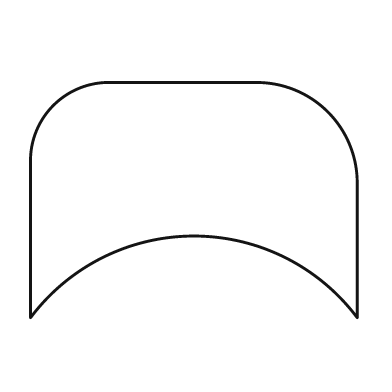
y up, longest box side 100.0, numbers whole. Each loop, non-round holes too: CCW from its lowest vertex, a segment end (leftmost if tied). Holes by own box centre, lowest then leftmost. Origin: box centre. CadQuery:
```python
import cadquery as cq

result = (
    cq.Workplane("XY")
    .moveTo(-50.0, -36.0)
    .threePointArc((0.0, -11.0), (50.0, -36.0))
    .lineTo(50.0, 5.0)
    .threePointArc((41.0, 27.0), (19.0, 36.0))
    .lineTo(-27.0, 36.0)
    .threePointArc((-43.0, 29.0), (-50.0, 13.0))
    .close()
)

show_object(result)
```